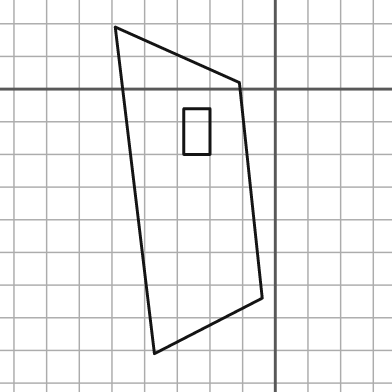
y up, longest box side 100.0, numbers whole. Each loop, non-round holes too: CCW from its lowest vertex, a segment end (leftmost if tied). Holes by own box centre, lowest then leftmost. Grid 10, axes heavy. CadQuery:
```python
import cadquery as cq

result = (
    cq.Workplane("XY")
    .moveTo(-37.0, -81.0)
    .lineTo(-4.0, -64.0)
    .lineTo(-11.0, 2.0)
    .lineTo(-49.0, 19.0)
    .close()
    .moveTo(-28.0, -20.0)
    .lineTo(-20.0, -20.0)
    .lineTo(-20.0, -6.0)
    .lineTo(-28.0, -6.0)
    .close()
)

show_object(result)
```